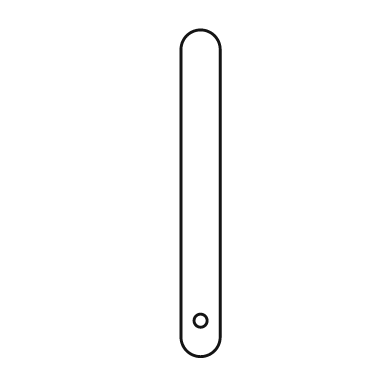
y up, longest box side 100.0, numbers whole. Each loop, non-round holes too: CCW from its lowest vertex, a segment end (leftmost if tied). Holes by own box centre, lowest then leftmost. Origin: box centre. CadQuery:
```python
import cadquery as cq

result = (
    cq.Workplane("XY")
    .moveTo(-6.0, -44.0)
    .threePointArc((0.0, -50.0), (6.0, -44.0))
    .lineTo(6.0, 44.0)
    .threePointArc((0.0, 50.0), (-6.0, 44.0))
    .close()
    .moveTo(0.0, -39.0)
    .circle(2.0)
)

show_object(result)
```